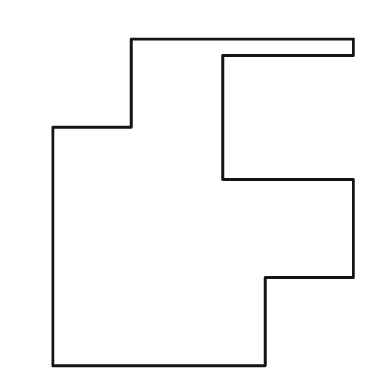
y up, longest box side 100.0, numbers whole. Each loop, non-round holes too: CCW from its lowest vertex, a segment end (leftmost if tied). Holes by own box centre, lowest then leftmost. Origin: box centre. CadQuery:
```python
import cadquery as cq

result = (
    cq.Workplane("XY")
    .moveTo(-46.0, -50.0)
    .lineTo(19.0, -50.0)
    .lineTo(19.0, -23.0)
    .lineTo(46.0, -23.0)
    .lineTo(46.0, 7.0)
    .lineTo(6.0, 7.0)
    .lineTo(6.0, 45.0)
    .lineTo(46.0, 45.0)
    .lineTo(46.0, 50.0)
    .lineTo(-22.0, 50.0)
    .lineTo(-22.0, 23.0)
    .lineTo(-46.0, 23.0)
    .close()
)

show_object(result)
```